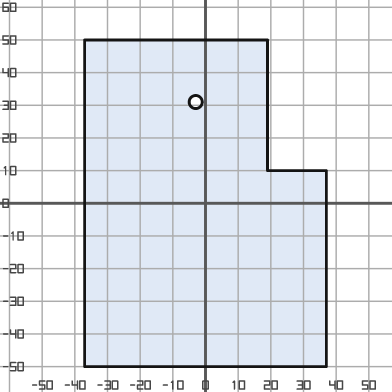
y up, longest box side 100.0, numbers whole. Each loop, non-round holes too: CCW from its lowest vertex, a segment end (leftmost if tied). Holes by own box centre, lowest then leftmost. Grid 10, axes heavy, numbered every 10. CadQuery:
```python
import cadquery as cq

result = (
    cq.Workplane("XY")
    .moveTo(-37.0, -50.0)
    .lineTo(37.0, -50.0)
    .lineTo(37.0, 10.0)
    .lineTo(19.0, 10.0)
    .lineTo(19.0, 50.0)
    .lineTo(-37.0, 50.0)
    .close()
    .moveTo(-3.0, 31.0)
    .circle(2.0)
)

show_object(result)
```